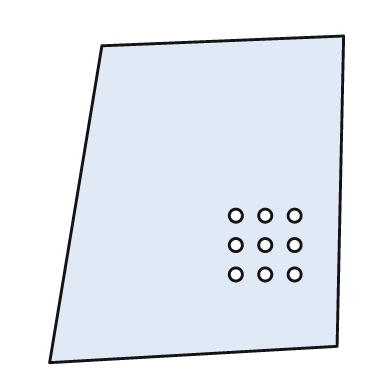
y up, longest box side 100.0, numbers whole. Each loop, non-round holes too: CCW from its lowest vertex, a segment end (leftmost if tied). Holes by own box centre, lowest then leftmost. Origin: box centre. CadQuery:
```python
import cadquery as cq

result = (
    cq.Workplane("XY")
    .moveTo(-45.0, -50.0)
    .lineTo(43.0, -45.0)
    .lineTo(45.0, 50.0)
    .lineTo(-29.0, 47.0)
    .close()
    .moveTo(12.0, -23.0)
    .circle(2.0)
    .moveTo(21.0, -23.0)
    .circle(2.0)
    .moveTo(30.0, -23.0)
    .circle(2.0)
    .moveTo(12.0, -14.0)
    .circle(2.0)
    .moveTo(21.0, -14.0)
    .circle(2.0)
    .moveTo(30.0, -14.0)
    .circle(2.0)
    .moveTo(12.0, -5.0)
    .circle(2.0)
    .moveTo(21.0, -5.0)
    .circle(2.0)
    .moveTo(30.0, -5.0)
    .circle(2.0)
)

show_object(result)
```